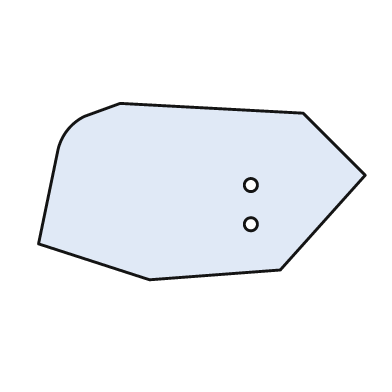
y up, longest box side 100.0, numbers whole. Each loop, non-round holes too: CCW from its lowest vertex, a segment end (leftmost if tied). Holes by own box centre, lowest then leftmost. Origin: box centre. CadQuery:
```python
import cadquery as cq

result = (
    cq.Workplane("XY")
    .moveTo(-16.0, -27.0)
    .lineTo(24.0, -24.0)
    .lineTo(50.0, 5.0)
    .lineTo(31.0, 24.0)
    .lineTo(-25.0, 27.0)
    .lineTo(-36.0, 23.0)
    .threePointArc((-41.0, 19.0), (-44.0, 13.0))
    .lineTo(-50.0, -16.0)
    .close()
    .moveTo(15.0, -10.0)
    .circle(2.0)
    .moveTo(15.0, 2.0)
    .circle(2.0)
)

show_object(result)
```